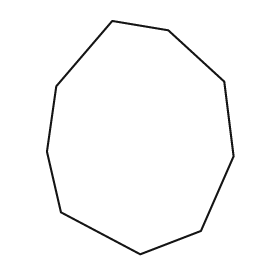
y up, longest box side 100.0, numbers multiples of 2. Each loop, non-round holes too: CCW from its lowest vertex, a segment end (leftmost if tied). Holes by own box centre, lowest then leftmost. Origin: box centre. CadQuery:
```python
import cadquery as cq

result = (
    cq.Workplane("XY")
    .moveTo(0.0, -50.0)
    .lineTo(26.0, -40.0)
    .lineTo(40.0, -8.0)
    .lineTo(36.0, 24.0)
    .lineTo(12.0, 46.0)
    .lineTo(-12.0, 50.0)
    .lineTo(-36.0, 22.0)
    .lineTo(-40.0, -6.0)
    .lineTo(-34.0, -32.0)
    .close()
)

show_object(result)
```